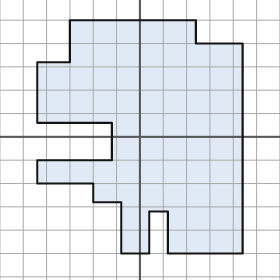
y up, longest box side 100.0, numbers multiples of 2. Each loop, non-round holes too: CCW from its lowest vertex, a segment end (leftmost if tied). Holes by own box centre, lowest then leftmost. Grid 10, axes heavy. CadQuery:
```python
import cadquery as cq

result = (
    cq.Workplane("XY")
    .moveTo(-8.0, -50.0)
    .lineTo(4.0, -50.0)
    .lineTo(4.0, -32.0)
    .lineTo(12.0, -32.0)
    .lineTo(12.0, -50.0)
    .lineTo(44.0, -50.0)
    .lineTo(44.0, 40.0)
    .lineTo(24.0, 40.0)
    .lineTo(24.0, 50.0)
    .lineTo(-30.0, 50.0)
    .lineTo(-30.0, 32.0)
    .lineTo(-44.0, 32.0)
    .lineTo(-44.0, 6.0)
    .lineTo(-12.0, 6.0)
    .lineTo(-12.0, -10.0)
    .lineTo(-44.0, -10.0)
    .lineTo(-44.0, -20.0)
    .lineTo(-20.0, -20.0)
    .lineTo(-20.0, -28.0)
    .lineTo(-8.0, -28.0)
    .close()
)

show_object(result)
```